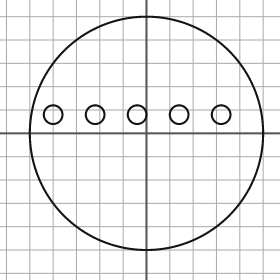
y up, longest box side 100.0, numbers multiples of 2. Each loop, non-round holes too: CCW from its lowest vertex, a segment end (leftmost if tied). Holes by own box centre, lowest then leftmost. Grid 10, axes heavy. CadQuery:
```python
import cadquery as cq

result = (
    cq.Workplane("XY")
    .moveTo(0.0, 0.0)
    .circle(50.0)
    .moveTo(-40.0, 8.0)
    .circle(4.0)
    .moveTo(-22.0, 8.0)
    .circle(4.0)
    .moveTo(-4.0, 8.0)
    .circle(4.0)
    .moveTo(14.0, 8.0)
    .circle(4.0)
    .moveTo(32.0, 8.0)
    .circle(4.0)
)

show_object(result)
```